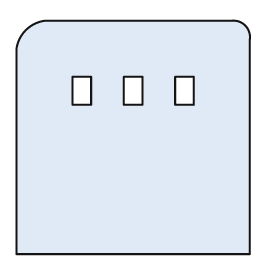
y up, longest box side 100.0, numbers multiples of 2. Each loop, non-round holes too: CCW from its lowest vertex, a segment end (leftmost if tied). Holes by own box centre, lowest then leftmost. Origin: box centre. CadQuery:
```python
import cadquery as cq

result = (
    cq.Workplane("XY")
    .moveTo(-50.0, -50.0)
    .lineTo(50.0, -50.0)
    .lineTo(50.0, 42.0)
    .threePointArc((48.0, 48.0), (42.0, 50.0))
    .lineTo(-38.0, 50.0)
    .threePointArc((-46.0, 46.0), (-50.0, 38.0))
    .close()
    .moveTo(-26.0, 14.0)
    .lineTo(-18.0, 14.0)
    .lineTo(-18.0, 26.0)
    .lineTo(-26.0, 26.0)
    .close()
    .moveTo(-4.0, 14.0)
    .lineTo(4.0, 14.0)
    .lineTo(4.0, 26.0)
    .lineTo(-4.0, 26.0)
    .close()
    .moveTo(18.0, 14.0)
    .lineTo(26.0, 14.0)
    .lineTo(26.0, 26.0)
    .lineTo(18.0, 26.0)
    .close()
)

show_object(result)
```